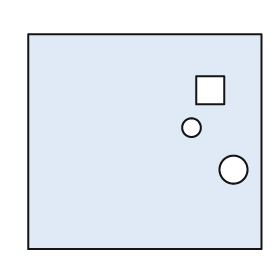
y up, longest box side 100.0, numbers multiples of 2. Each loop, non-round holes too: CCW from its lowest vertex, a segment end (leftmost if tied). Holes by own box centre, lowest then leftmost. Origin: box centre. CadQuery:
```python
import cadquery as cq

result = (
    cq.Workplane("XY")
    .moveTo(-50.0, -46.0)
    .lineTo(50.0, -46.0)
    .lineTo(50.0, 46.0)
    .lineTo(-50.0, 46.0)
    .close()
    .moveTo(38.0, -12.0)
    .circle(6.0)
    .moveTo(20.0, 6.0)
    .circle(4.0)
    .moveTo(22.0, 16.0)
    .lineTo(34.0, 16.0)
    .lineTo(34.0, 28.0)
    .lineTo(22.0, 28.0)
    .close()
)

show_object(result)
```